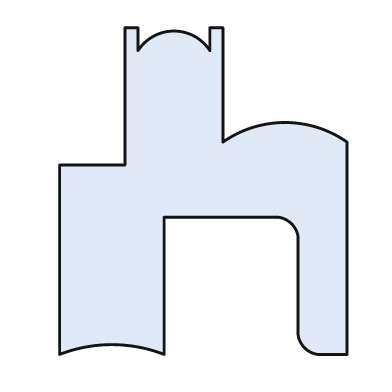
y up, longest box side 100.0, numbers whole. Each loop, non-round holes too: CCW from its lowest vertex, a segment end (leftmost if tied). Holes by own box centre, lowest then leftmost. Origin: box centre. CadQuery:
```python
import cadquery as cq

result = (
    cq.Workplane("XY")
    .moveTo(-44.0, -50.0)
    .threePointArc((-28.0, -47.0), (-12.0, -50.0))
    .lineTo(-12.0, -8.0)
    .lineTo(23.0, -8.0)
    .threePointArc((27.0, -10.0), (29.0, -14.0))
    .lineTo(29.0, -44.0)
    .threePointArc((31.0, -48.0), (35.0, -50.0))
    .lineTo(44.0, -50.0)
    .lineTo(44.0, 15.0)
    .threePointArc((25.0, 21.0), (6.0, 15.0))
    .lineTo(6.0, 50.0)
    .lineTo(2.0, 50.0)
    .lineTo(2.0, 43.0)
    .threePointArc((-9.0, 49.0), (-20.0, 43.0))
    .lineTo(-20.0, 50.0)
    .lineTo(-24.0, 50.0)
    .lineTo(-24.0, 8.0)
    .lineTo(-44.0, 8.0)
    .close()
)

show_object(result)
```